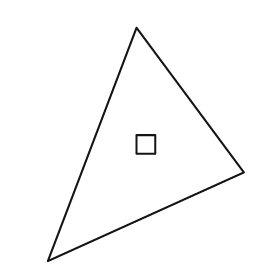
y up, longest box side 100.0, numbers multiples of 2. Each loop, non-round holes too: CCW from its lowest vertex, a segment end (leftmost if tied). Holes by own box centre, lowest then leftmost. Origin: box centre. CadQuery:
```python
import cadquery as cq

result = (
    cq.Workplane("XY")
    .moveTo(-42.0, -50.0)
    .lineTo(42.0, -12.0)
    .lineTo(-4.0, 50.0)
    .close()
    .moveTo(-4.0, -4.0)
    .lineTo(4.0, -4.0)
    .lineTo(4.0, 4.0)
    .lineTo(-4.0, 4.0)
    .close()
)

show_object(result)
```